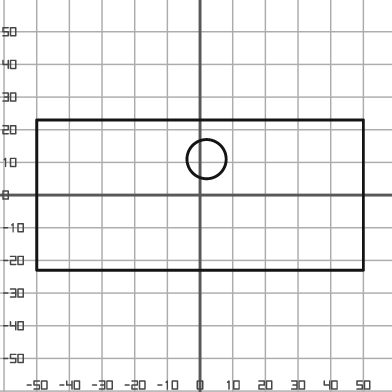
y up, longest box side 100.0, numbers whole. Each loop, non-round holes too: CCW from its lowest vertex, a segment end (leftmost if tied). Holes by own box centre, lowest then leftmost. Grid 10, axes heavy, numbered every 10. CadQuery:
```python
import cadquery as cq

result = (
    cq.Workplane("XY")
    .moveTo(-50.0, -23.0)
    .lineTo(50.0, -23.0)
    .lineTo(50.0, 23.0)
    .lineTo(-50.0, 23.0)
    .close()
    .moveTo(2.0, 11.0)
    .circle(6.0)
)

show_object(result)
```